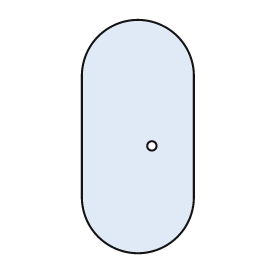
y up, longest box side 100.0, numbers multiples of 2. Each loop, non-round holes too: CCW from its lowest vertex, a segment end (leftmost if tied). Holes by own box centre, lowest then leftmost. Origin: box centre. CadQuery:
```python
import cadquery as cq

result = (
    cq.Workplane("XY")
    .moveTo(-24.0, -26.0)
    .threePointArc((0.0, -50.0), (24.0, -26.0))
    .lineTo(24.0, 26.0)
    .threePointArc((0.0, 50.0), (-24.0, 26.0))
    .close()
    .moveTo(6.0, -4.0)
    .circle(2.0)
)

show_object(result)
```